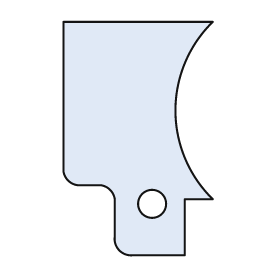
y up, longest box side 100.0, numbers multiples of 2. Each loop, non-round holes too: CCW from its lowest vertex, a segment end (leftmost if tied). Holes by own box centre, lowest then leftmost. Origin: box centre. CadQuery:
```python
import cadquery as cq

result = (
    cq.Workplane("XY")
    .moveTo(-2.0, -50.0)
    .lineTo(20.0, -50.0)
    .lineTo(20.0, -26.0)
    .lineTo(32.0, -26.0)
    .threePointArc((16.0, 12.0), (32.0, 50.0))
    .lineTo(-32.0, 50.0)
    .lineTo(-32.0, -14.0)
    .threePointArc((-30.0, -18.0), (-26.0, -20.0))
    .lineTo(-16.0, -20.0)
    .threePointArc((-12.0, -22.0), (-10.0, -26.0))
    .lineTo(-10.0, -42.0)
    .threePointArc((-8.0, -48.0), (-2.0, -50.0))
    .close()
    .moveTo(6.0, -28.0)
    .circle(6.0)
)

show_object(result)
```